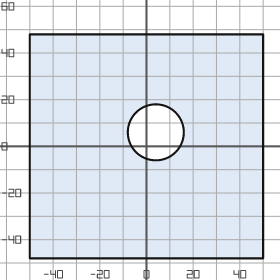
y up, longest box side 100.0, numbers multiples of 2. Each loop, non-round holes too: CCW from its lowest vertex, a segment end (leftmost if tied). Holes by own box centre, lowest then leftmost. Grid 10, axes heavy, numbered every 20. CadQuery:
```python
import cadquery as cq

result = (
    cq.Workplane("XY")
    .moveTo(-50.0, -48.0)
    .lineTo(50.0, -48.0)
    .lineTo(50.0, 48.0)
    .lineTo(-50.0, 48.0)
    .close()
    .moveTo(4.0, 6.0)
    .circle(12.0)
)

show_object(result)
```